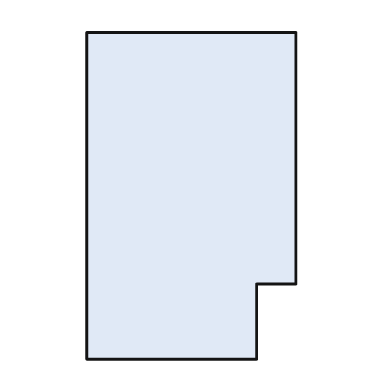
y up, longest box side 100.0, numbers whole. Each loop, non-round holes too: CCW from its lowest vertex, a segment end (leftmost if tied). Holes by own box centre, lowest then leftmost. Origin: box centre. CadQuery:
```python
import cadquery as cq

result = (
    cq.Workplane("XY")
    .moveTo(-32.0, -50.0)
    .lineTo(20.0, -50.0)
    .lineTo(20.0, -27.0)
    .lineTo(32.0, -27.0)
    .lineTo(32.0, 50.0)
    .lineTo(-32.0, 50.0)
    .close()
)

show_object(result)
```